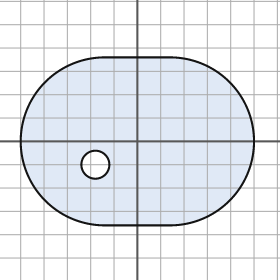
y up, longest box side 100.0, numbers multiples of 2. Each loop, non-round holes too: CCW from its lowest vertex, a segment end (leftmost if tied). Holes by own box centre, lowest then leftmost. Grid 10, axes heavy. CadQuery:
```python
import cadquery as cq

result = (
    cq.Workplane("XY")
    .moveTo(-14.0, -36.0)
    .lineTo(14.0, -36.0)
    .threePointArc((50.0, 0.0), (14.0, 36.0))
    .lineTo(-14.0, 36.0)
    .threePointArc((-50.0, 0.0), (-14.0, -36.0))
    .close()
    .moveTo(-18.0, -10.0)
    .circle(6.0)
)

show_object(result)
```